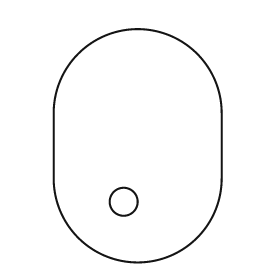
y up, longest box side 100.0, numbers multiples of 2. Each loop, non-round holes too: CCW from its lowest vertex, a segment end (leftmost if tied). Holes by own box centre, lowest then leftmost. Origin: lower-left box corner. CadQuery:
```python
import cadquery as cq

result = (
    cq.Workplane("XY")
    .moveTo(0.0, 36.0)
    .threePointArc((36.0, 0.0), (72.0, 36.0))
    .lineTo(72.0, 64.0)
    .threePointArc((36.0, 100.0), (0.0, 64.0))
    .close()
    .moveTo(30.0, 26.0)
    .circle(6.0)
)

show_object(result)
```